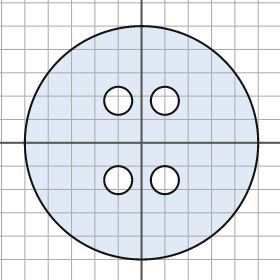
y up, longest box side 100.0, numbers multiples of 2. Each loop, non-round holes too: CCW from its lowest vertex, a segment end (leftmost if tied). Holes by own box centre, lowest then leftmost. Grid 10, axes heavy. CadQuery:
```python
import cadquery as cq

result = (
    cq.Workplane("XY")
    .moveTo(0.0, 0.0)
    .circle(50.0)
    .moveTo(-10.0, -16.0)
    .circle(6.0)
    .moveTo(10.0, -16.0)
    .circle(6.0)
    .moveTo(-10.0, 18.0)
    .circle(6.0)
    .moveTo(10.0, 18.0)
    .circle(6.0)
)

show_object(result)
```